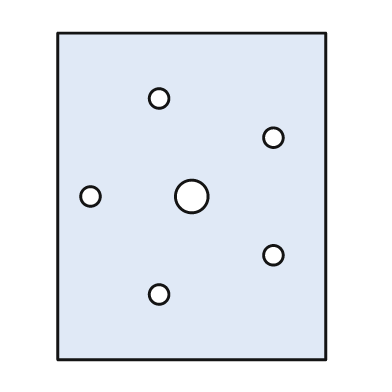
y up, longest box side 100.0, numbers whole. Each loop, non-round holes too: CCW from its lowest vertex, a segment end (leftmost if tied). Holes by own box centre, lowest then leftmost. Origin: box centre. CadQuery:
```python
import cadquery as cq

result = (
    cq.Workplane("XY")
    .moveTo(-41.0, -50.0)
    .lineTo(41.0, -50.0)
    .lineTo(41.0, 50.0)
    .lineTo(-41.0, 50.0)
    .close()
    .moveTo(-10.0, -30.0)
    .circle(3.0)
    .moveTo(25.0, -18.0)
    .circle(3.0)
    .moveTo(-31.0, 0.0)
    .circle(3.0)
    .moveTo(0.0, 0.0)
    .circle(5.0)
    .moveTo(25.0, 18.0)
    .circle(3.0)
    .moveTo(-10.0, 30.0)
    .circle(3.0)
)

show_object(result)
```